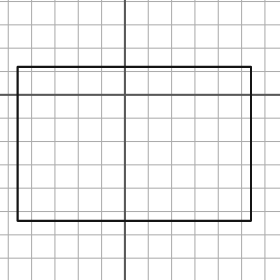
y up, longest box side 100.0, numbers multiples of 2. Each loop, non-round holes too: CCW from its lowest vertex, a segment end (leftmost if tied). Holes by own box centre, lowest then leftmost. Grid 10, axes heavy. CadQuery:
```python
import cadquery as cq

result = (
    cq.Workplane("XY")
    .moveTo(-46.0, -54.0)
    .lineTo(54.0, -54.0)
    .lineTo(54.0, 12.0)
    .lineTo(-46.0, 12.0)
    .close()
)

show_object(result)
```